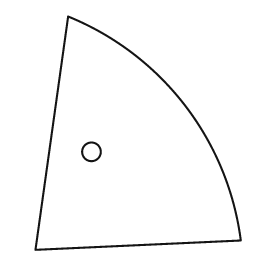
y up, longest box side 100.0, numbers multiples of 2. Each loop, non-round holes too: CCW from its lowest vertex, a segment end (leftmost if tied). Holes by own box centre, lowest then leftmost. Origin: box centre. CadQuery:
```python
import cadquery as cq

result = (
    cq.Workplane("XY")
    .moveTo(-44.0, -50.0)
    .lineTo(44.0, -46.0)
    .threePointArc((20.0, 12.0), (-30.0, 50.0))
    .close()
    .moveTo(-20.0, -8.0)
    .circle(4.0)
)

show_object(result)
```